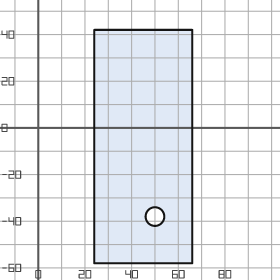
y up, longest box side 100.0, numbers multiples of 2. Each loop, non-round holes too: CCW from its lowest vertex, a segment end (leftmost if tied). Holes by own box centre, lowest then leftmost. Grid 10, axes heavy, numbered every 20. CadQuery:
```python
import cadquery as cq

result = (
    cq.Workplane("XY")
    .moveTo(24.0, -58.0)
    .lineTo(66.0, -58.0)
    .lineTo(66.0, 42.0)
    .lineTo(24.0, 42.0)
    .close()
    .moveTo(50.0, -38.0)
    .circle(4.0)
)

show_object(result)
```